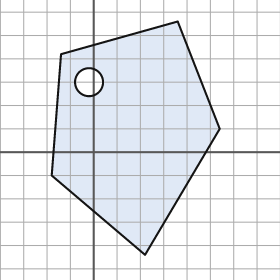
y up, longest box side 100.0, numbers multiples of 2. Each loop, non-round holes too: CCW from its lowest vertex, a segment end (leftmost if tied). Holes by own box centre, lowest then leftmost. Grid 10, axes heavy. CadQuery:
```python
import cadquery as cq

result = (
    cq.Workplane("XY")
    .moveTo(22.0, -44.0)
    .lineTo(54.0, 10.0)
    .lineTo(36.0, 56.0)
    .lineTo(-14.0, 42.0)
    .lineTo(-18.0, -10.0)
    .close()
    .moveTo(-2.0, 30.0)
    .circle(6.0)
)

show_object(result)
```